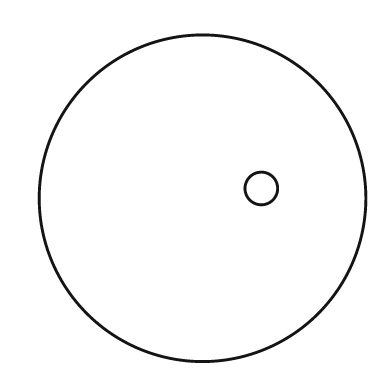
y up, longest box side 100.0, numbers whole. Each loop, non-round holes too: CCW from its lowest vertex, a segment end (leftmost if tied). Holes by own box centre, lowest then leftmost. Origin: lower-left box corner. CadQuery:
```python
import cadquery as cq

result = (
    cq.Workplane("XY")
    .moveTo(50.0, 50.0)
    .circle(50.0)
    .moveTo(68.0, 53.0)
    .circle(5.0)
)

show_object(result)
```